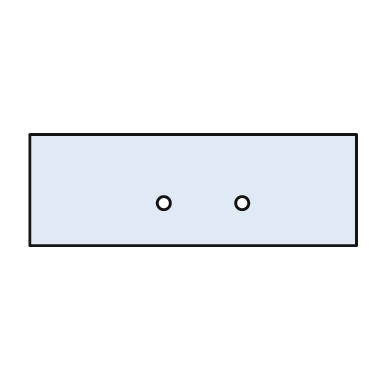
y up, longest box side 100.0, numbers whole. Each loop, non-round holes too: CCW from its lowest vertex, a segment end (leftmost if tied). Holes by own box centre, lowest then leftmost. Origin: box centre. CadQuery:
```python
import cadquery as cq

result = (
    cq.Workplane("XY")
    .moveTo(-50.0, -17.0)
    .lineTo(50.0, -17.0)
    .lineTo(50.0, 17.0)
    .lineTo(-50.0, 17.0)
    .close()
    .moveTo(-9.0, -4.0)
    .circle(2.0)
    .moveTo(15.0, -4.0)
    .circle(2.0)
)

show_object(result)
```